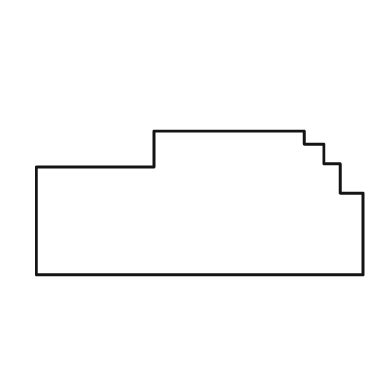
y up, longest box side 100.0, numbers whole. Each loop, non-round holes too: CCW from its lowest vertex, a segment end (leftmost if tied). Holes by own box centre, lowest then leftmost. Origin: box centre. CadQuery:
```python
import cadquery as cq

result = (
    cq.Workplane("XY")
    .moveTo(-50.0, -22.0)
    .lineTo(50.0, -22.0)
    .lineTo(50.0, 3.0)
    .lineTo(43.0, 3.0)
    .lineTo(43.0, 12.0)
    .lineTo(38.0, 12.0)
    .lineTo(38.0, 18.0)
    .lineTo(32.0, 18.0)
    .lineTo(32.0, 22.0)
    .lineTo(-14.0, 22.0)
    .lineTo(-14.0, 11.0)
    .lineTo(-50.0, 11.0)
    .close()
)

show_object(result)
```